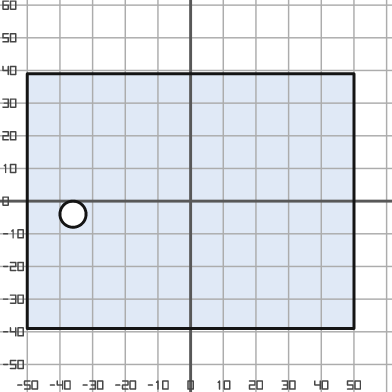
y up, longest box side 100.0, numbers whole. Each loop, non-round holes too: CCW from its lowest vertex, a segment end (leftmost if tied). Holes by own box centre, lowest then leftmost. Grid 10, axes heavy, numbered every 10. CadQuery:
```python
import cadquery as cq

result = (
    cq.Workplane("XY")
    .moveTo(-50.0, -39.0)
    .lineTo(50.0, -39.0)
    .lineTo(50.0, 39.0)
    .lineTo(-50.0, 39.0)
    .close()
    .moveTo(-36.0, -4.0)
    .circle(4.0)
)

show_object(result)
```